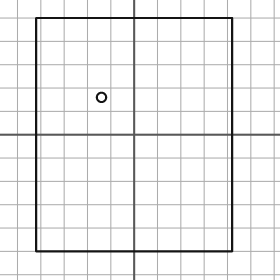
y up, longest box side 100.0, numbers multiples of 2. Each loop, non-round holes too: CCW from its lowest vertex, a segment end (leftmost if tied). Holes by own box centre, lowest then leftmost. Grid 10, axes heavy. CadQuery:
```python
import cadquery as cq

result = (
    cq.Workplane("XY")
    .moveTo(-42.0, -50.0)
    .lineTo(42.0, -50.0)
    .lineTo(42.0, 50.0)
    .lineTo(-42.0, 50.0)
    .close()
    .moveTo(-14.0, 16.0)
    .circle(2.0)
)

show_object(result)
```